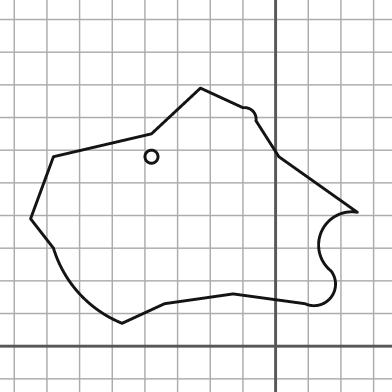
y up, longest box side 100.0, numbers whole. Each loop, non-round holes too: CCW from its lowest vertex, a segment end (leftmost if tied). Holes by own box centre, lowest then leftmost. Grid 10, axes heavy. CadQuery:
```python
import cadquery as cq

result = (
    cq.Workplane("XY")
    .moveTo(-47.0, 7.0)
    .lineTo(-34.0, 13.0)
    .lineTo(-13.0, 16.0)
    .lineTo(9.0, 13.0)
    .threePointArc((17.0, 15.0), (17.0, 23.0))
    .threePointArc((14.0, 35.0), (25.0, 41.0))
    .lineTo(1.0, 58.0)
    .lineTo(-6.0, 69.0)
    .threePointArc((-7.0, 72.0), (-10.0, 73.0))
    .lineTo(-23.0, 79.0)
    .lineTo(-38.0, 65.0)
    .lineTo(-68.0, 58.0)
    .lineTo(-75.0, 39.0)
    .lineTo(-68.0, 30.0)
    .threePointArc((-60.0, 16.0), (-47.0, 7.0))
    .close()
    .moveTo(-38.0, 58.0)
    .circle(2.0)
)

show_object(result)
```